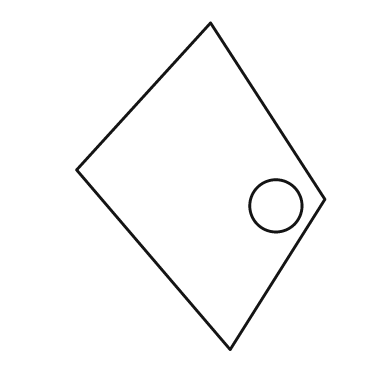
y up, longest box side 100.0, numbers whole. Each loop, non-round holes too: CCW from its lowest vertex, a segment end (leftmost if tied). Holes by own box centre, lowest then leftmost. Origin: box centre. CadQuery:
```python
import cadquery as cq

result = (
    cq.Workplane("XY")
    .moveTo(9.0, -50.0)
    .lineTo(38.0, -4.0)
    .lineTo(3.0, 50.0)
    .lineTo(-38.0, 5.0)
    .close()
    .moveTo(23.0, -6.0)
    .circle(8.0)
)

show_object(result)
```